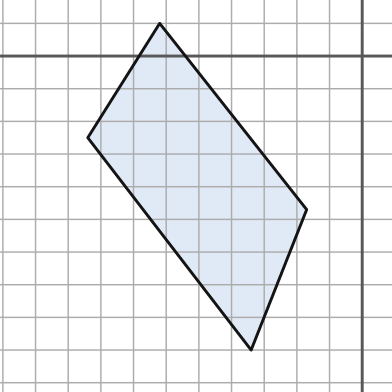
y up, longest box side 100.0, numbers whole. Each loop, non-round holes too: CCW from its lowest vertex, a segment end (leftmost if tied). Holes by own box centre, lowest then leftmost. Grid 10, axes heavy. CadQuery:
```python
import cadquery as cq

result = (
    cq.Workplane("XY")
    .moveTo(-34.0, -90.0)
    .lineTo(-17.0, -47.0)
    .lineTo(-62.0, 10.0)
    .lineTo(-84.0, -25.0)
    .close()
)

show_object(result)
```